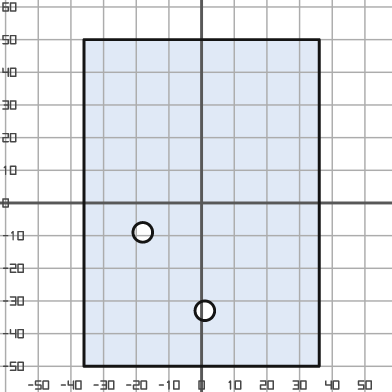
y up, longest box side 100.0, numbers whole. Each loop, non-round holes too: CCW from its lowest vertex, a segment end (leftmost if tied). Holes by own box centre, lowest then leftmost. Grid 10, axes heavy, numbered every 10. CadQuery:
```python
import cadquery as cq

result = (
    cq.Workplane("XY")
    .moveTo(-36.0, -50.0)
    .lineTo(36.0, -50.0)
    .lineTo(36.0, 50.0)
    .lineTo(-36.0, 50.0)
    .close()
    .moveTo(1.0, -33.0)
    .circle(3.0)
    .moveTo(-18.0, -9.0)
    .circle(3.0)
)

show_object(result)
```